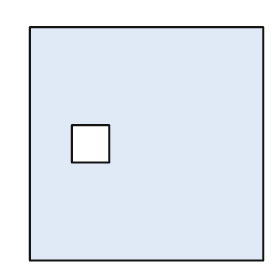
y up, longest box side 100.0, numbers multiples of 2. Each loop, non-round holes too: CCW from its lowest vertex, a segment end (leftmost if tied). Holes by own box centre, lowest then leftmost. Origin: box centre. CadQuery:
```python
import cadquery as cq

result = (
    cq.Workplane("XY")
    .moveTo(-50.0, -50.0)
    .lineTo(50.0, -50.0)
    .lineTo(50.0, 50.0)
    .lineTo(-50.0, 50.0)
    .close()
    .moveTo(-32.0, -8.0)
    .lineTo(-16.0, -8.0)
    .lineTo(-16.0, 8.0)
    .lineTo(-32.0, 8.0)
    .close()
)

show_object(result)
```